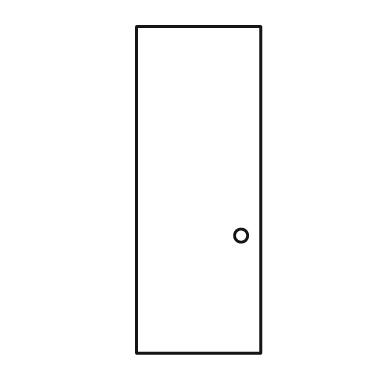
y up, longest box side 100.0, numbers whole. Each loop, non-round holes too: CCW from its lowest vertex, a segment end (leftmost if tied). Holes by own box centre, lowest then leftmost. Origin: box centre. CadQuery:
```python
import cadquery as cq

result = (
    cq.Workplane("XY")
    .moveTo(-19.0, -50.0)
    .lineTo(19.0, -50.0)
    .lineTo(19.0, 50.0)
    .lineTo(-19.0, 50.0)
    .close()
    .moveTo(13.0, -14.0)
    .circle(2.0)
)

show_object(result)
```